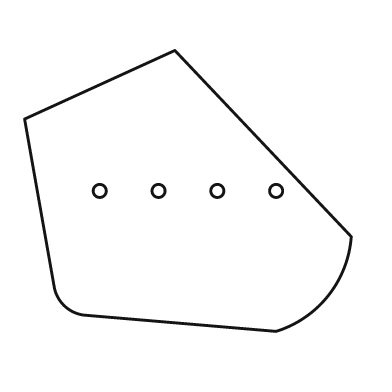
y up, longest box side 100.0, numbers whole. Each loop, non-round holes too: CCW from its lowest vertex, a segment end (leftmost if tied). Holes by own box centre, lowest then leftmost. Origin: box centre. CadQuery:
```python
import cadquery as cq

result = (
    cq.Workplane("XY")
    .moveTo(27.0, -43.0)
    .threePointArc((43.0, -32.0), (50.0, -14.0))
    .lineTo(-4.0, 43.0)
    .lineTo(-50.0, 22.0)
    .lineTo(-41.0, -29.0)
    .threePointArc((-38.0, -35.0), (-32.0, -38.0))
    .close()
    .moveTo(-27.0, 0.0)
    .circle(2.0)
    .moveTo(-9.0, 0.0)
    .circle(2.0)
    .moveTo(9.0, 0.0)
    .circle(2.0)
    .moveTo(27.0, 0.0)
    .circle(2.0)
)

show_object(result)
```